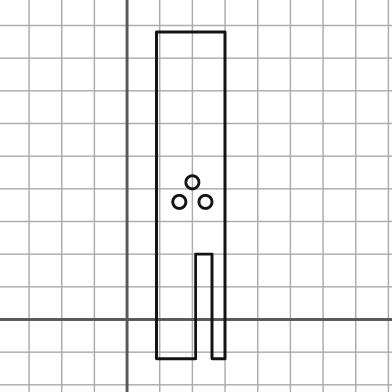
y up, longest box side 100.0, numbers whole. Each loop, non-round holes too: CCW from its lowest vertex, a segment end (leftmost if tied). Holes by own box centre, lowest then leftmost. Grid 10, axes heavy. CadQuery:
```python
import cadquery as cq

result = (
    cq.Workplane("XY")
    .moveTo(9.0, -12.0)
    .lineTo(21.0, -12.0)
    .lineTo(21.0, 20.0)
    .lineTo(26.0, 20.0)
    .lineTo(26.0, -12.0)
    .lineTo(30.0, -12.0)
    .lineTo(30.0, 88.0)
    .lineTo(9.0, 88.0)
    .close()
    .moveTo(16.0, 36.0)
    .circle(2.0)
    .moveTo(24.0, 36.0)
    .circle(2.0)
    .moveTo(20.0, 42.0)
    .circle(2.0)
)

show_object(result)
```